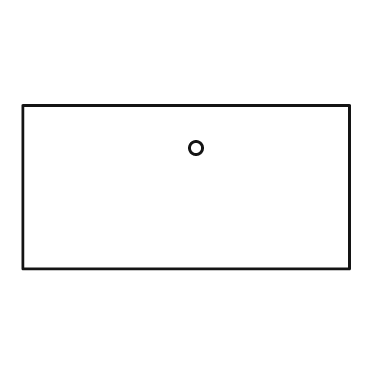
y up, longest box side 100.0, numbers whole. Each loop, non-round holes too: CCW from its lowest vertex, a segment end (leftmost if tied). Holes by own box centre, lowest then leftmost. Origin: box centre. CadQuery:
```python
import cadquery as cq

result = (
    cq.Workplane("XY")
    .moveTo(-50.0, -25.0)
    .lineTo(50.0, -25.0)
    .lineTo(50.0, 25.0)
    .lineTo(-50.0, 25.0)
    .close()
    .moveTo(3.0, 12.0)
    .circle(2.0)
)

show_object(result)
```